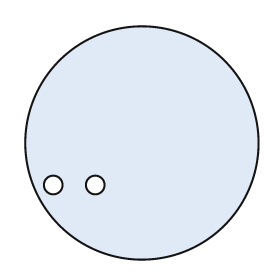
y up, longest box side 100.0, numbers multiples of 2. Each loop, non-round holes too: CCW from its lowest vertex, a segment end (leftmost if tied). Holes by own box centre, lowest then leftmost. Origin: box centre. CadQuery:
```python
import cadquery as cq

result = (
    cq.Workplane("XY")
    .moveTo(0.0, 0.0)
    .circle(50.0)
    .moveTo(-38.0, -18.0)
    .circle(4.0)
    .moveTo(-20.0, -18.0)
    .circle(4.0)
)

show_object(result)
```